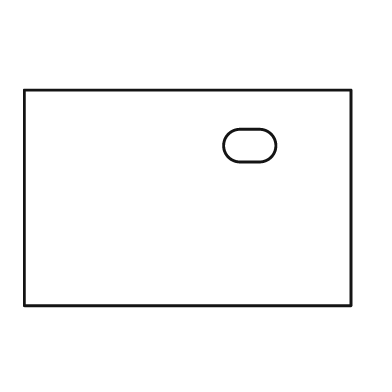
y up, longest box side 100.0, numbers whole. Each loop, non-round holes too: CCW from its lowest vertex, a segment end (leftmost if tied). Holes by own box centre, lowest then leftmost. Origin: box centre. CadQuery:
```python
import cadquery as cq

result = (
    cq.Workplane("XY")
    .moveTo(-50.0, -33.0)
    .lineTo(50.0, -33.0)
    .lineTo(50.0, 33.0)
    .lineTo(-50.0, 33.0)
    .close()
    .moveTo(16.0, 11.0)
    .lineTo(22.0, 11.0)
    .threePointArc((27.0, 16.0), (22.0, 21.0))
    .lineTo(16.0, 21.0)
    .threePointArc((11.0, 16.0), (16.0, 11.0))
    .close()
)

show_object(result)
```